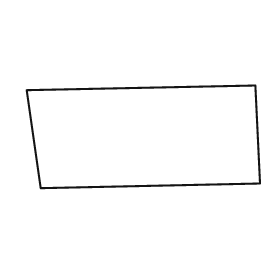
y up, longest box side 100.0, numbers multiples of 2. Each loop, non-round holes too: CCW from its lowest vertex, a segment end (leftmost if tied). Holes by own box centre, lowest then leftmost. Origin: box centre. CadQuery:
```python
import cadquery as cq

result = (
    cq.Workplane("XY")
    .moveTo(-44.0, -22.0)
    .lineTo(50.0, -20.0)
    .lineTo(48.0, 22.0)
    .lineTo(-50.0, 20.0)
    .close()
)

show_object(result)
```